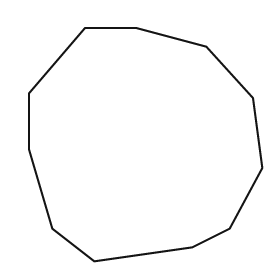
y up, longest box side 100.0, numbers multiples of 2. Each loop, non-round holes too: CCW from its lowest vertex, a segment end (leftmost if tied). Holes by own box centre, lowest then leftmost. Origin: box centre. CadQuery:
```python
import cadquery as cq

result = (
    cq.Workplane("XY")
    .moveTo(-22.0, -50.0)
    .lineTo(20.0, -44.0)
    .lineTo(36.0, -36.0)
    .lineTo(50.0, -10.0)
    .lineTo(46.0, 20.0)
    .lineTo(26.0, 42.0)
    .lineTo(-4.0, 50.0)
    .lineTo(-26.0, 50.0)
    .lineTo(-50.0, 22.0)
    .lineTo(-50.0, -2.0)
    .lineTo(-40.0, -36.0)
    .close()
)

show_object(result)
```